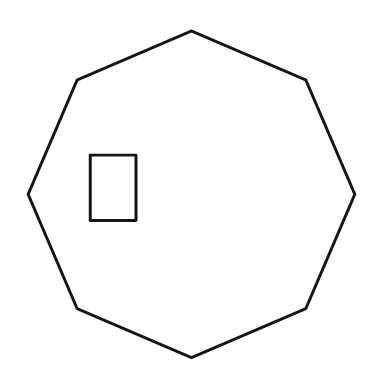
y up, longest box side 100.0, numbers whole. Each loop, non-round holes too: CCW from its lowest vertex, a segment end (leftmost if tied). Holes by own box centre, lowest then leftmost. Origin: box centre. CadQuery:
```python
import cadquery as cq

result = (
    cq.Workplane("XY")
    .moveTo(0.0, -50.0)
    .lineTo(35.0, -35.0)
    .lineTo(50.0, 0.0)
    .lineTo(35.0, 35.0)
    .lineTo(0.0, 50.0)
    .lineTo(-35.0, 35.0)
    .lineTo(-50.0, 0.0)
    .lineTo(-35.0, -35.0)
    .close()
    .moveTo(-31.0, -8.0)
    .lineTo(-17.0, -8.0)
    .lineTo(-17.0, 12.0)
    .lineTo(-31.0, 12.0)
    .close()
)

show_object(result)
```